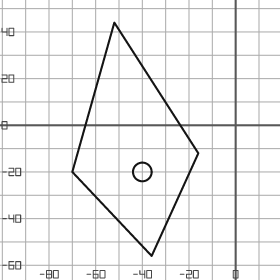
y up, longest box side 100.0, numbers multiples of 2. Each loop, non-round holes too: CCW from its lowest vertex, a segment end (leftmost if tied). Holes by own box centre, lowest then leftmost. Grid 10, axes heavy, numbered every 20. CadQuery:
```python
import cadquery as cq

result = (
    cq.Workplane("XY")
    .moveTo(-36.0, -56.0)
    .lineTo(-16.0, -12.0)
    .lineTo(-52.0, 44.0)
    .lineTo(-70.0, -20.0)
    .close()
    .moveTo(-40.0, -20.0)
    .circle(4.0)
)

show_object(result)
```